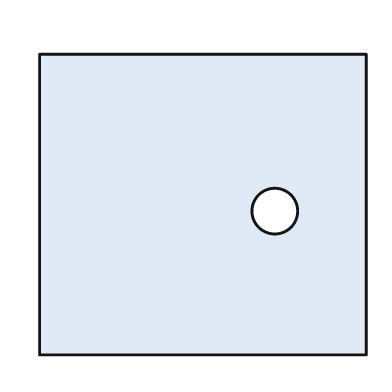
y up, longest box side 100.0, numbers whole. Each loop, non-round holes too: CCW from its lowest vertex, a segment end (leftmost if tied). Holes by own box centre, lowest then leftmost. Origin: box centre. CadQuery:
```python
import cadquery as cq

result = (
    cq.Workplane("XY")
    .moveTo(-50.0, -46.0)
    .lineTo(50.0, -46.0)
    .lineTo(50.0, 46.0)
    .lineTo(-50.0, 46.0)
    .close()
    .moveTo(22.0, -2.0)
    .circle(7.0)
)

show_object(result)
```